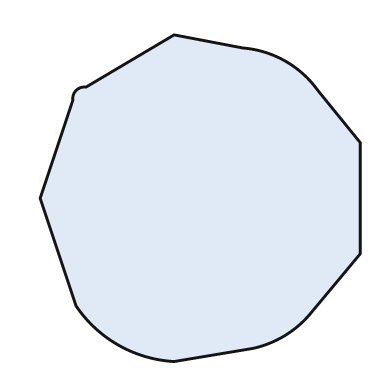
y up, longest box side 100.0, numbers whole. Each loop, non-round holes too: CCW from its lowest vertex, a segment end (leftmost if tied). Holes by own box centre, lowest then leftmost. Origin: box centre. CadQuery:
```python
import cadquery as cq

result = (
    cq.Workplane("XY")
    .moveTo(-8.0, -50.0)
    .lineTo(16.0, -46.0)
    .threePointArc((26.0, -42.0), (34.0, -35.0))
    .lineTo(49.0, -17.0)
    .lineTo(49.0, 17.0)
    .lineTo(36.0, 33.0)
    .threePointArc((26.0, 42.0), (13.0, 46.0))
    .lineTo(-8.0, 50.0)
    .lineTo(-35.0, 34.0)
    .threePointArc((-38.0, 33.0), (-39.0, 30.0))
    .lineTo(-49.0, 0.0)
    .lineTo(-38.0, -33.0)
    .threePointArc((-25.0, -45.0), (-8.0, -50.0))
    .close()
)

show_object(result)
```